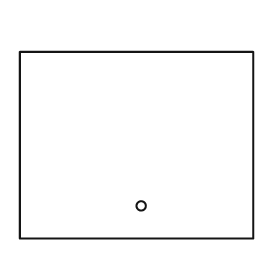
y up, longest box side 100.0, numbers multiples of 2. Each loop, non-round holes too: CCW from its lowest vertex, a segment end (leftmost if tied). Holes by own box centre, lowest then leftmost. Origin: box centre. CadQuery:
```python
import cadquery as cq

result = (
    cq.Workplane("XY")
    .moveTo(-50.0, -40.0)
    .lineTo(50.0, -40.0)
    .lineTo(50.0, 40.0)
    .lineTo(-50.0, 40.0)
    .close()
    .moveTo(2.0, -26.0)
    .circle(2.0)
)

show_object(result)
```